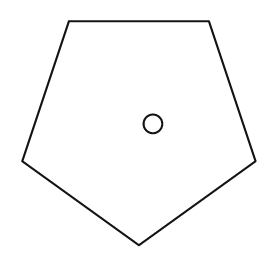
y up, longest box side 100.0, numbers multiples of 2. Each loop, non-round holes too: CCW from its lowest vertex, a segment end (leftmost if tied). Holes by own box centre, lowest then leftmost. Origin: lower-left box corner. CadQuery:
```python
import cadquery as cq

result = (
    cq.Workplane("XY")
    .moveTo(50.0, 0.0)
    .lineTo(100.0, 36.0)
    .lineTo(80.0, 96.0)
    .lineTo(20.0, 96.0)
    .lineTo(0.0, 36.0)
    .close()
    .moveTo(56.0, 52.0)
    .circle(4.0)
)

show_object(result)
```